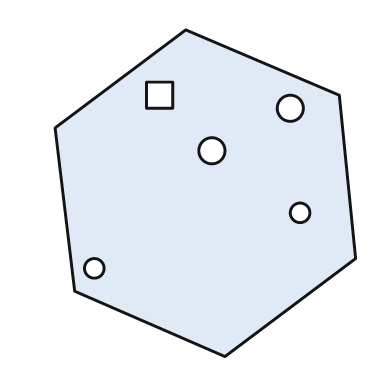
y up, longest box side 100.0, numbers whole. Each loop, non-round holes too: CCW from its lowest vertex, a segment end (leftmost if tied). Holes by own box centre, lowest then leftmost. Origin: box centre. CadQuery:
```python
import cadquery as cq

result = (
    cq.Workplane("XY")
    .moveTo(6.0, -50.0)
    .lineTo(46.0, -20.0)
    .lineTo(41.0, 30.0)
    .lineTo(-6.0, 50.0)
    .lineTo(-46.0, 20.0)
    .lineTo(-40.0, -30.0)
    .close()
    .moveTo(-34.0, -23.0)
    .circle(3.0)
    .moveTo(29.0, -6.0)
    .circle(3.0)
    .moveTo(2.0, 13.0)
    .circle(4.0)
    .moveTo(26.0, 26.0)
    .circle(4.0)
    .moveTo(-18.0, 26.0)
    .lineTo(-10.0, 26.0)
    .lineTo(-10.0, 34.0)
    .lineTo(-18.0, 34.0)
    .close()
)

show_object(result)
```